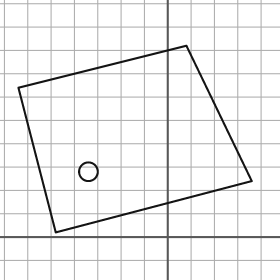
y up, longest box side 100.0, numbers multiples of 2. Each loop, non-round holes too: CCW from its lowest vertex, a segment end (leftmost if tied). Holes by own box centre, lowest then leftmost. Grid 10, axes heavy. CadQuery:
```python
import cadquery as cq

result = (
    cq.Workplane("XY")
    .moveTo(-48.0, 2.0)
    .lineTo(36.0, 24.0)
    .lineTo(8.0, 82.0)
    .lineTo(-64.0, 64.0)
    .close()
    .moveTo(-34.0, 28.0)
    .circle(4.0)
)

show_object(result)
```